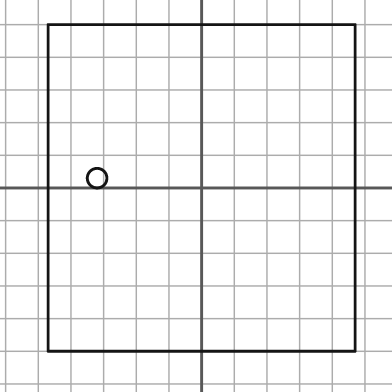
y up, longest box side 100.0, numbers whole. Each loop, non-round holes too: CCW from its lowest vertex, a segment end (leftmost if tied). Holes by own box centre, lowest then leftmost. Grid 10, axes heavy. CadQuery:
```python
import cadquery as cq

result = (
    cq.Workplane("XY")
    .moveTo(-47.0, -50.0)
    .lineTo(47.0, -50.0)
    .lineTo(47.0, 50.0)
    .lineTo(-47.0, 50.0)
    .close()
    .moveTo(-32.0, 3.0)
    .circle(3.0)
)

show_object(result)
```